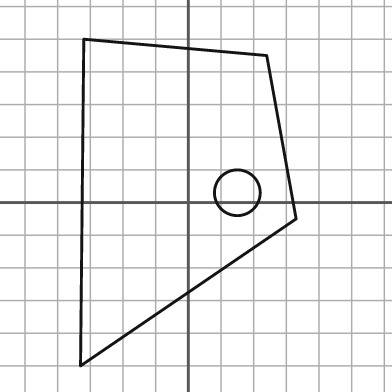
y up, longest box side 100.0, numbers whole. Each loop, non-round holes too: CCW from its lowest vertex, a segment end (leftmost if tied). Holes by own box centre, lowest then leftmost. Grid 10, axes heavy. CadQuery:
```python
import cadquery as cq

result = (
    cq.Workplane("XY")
    .moveTo(-33.0, -50.0)
    .lineTo(33.0, -5.0)
    .lineTo(24.0, 45.0)
    .lineTo(-32.0, 50.0)
    .close()
    .moveTo(15.0, 3.0)
    .circle(7.0)
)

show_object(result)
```